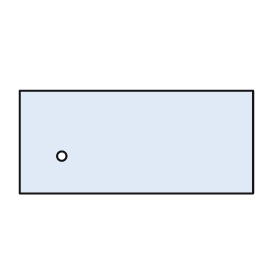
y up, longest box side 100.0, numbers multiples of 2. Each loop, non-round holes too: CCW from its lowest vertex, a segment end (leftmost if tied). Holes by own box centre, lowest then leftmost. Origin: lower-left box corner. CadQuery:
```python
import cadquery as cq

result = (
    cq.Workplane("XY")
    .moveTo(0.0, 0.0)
    .lineTo(100.0, 0.0)
    .lineTo(100.0, 44.0)
    .lineTo(0.0, 44.0)
    .close()
    .moveTo(18.0, 16.0)
    .circle(2.0)
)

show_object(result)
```